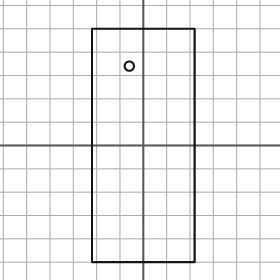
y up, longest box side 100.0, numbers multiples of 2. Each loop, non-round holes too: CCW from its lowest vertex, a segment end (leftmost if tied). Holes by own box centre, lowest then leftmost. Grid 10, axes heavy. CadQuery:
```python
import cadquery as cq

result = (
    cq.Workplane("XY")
    .moveTo(-22.0, -50.0)
    .lineTo(22.0, -50.0)
    .lineTo(22.0, 50.0)
    .lineTo(-22.0, 50.0)
    .close()
    .moveTo(-6.0, 34.0)
    .circle(2.0)
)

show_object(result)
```